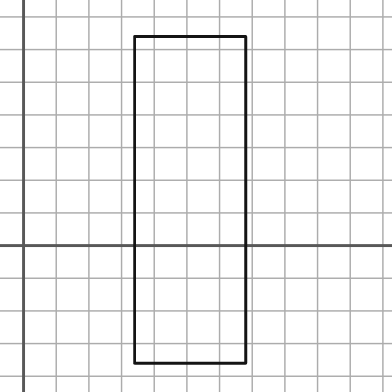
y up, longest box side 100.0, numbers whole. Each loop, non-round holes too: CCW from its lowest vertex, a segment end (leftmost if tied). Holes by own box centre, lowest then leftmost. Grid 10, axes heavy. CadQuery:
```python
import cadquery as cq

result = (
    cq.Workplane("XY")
    .moveTo(34.0, -36.0)
    .lineTo(68.0, -36.0)
    .lineTo(68.0, 64.0)
    .lineTo(34.0, 64.0)
    .close()
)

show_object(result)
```